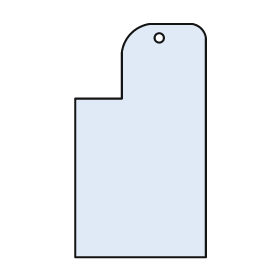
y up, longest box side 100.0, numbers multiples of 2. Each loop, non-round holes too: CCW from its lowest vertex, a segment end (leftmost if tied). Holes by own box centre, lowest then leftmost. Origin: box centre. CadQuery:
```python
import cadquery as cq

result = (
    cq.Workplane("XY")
    .moveTo(-28.0, -50.0)
    .lineTo(28.0, -50.0)
    .lineTo(28.0, 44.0)
    .threePointArc((26.0, 48.0), (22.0, 50.0))
    .lineTo(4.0, 50.0)
    .threePointArc((-4.0, 46.0), (-8.0, 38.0))
    .lineTo(-8.0, 18.0)
    .lineTo(-28.0, 18.0)
    .close()
    .moveTo(8.0, 44.0)
    .circle(2.0)
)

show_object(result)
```